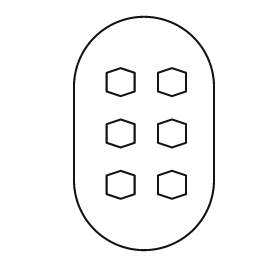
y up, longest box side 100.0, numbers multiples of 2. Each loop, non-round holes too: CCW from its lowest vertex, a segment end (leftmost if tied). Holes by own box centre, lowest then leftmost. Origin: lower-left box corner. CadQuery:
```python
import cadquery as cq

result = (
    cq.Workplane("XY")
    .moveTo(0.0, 30.0)
    .threePointArc((30.0, 0.0), (60.0, 30.0))
    .lineTo(60.0, 70.0)
    .threePointArc((30.0, 100.0), (0.0, 70.0))
    .close()
    .moveTo(20.0, 22.0)
    .lineTo(26.0, 24.0)
    .lineTo(26.0, 32.0)
    .lineTo(20.0, 34.0)
    .lineTo(14.0, 32.0)
    .lineTo(14.0, 24.0)
    .close()
    .moveTo(42.0, 22.0)
    .lineTo(48.0, 24.0)
    .lineTo(48.0, 32.0)
    .lineTo(42.0, 34.0)
    .lineTo(36.0, 32.0)
    .lineTo(36.0, 24.0)
    .close()
    .moveTo(20.0, 44.0)
    .lineTo(26.0, 46.0)
    .lineTo(26.0, 54.0)
    .lineTo(20.0, 56.0)
    .lineTo(14.0, 54.0)
    .lineTo(14.0, 46.0)
    .close()
    .moveTo(42.0, 44.0)
    .lineTo(48.0, 46.0)
    .lineTo(48.0, 54.0)
    .lineTo(42.0, 56.0)
    .lineTo(36.0, 54.0)
    .lineTo(36.0, 46.0)
    .close()
    .moveTo(20.0, 66.0)
    .lineTo(26.0, 68.0)
    .lineTo(26.0, 76.0)
    .lineTo(20.0, 78.0)
    .lineTo(14.0, 76.0)
    .lineTo(14.0, 68.0)
    .close()
    .moveTo(42.0, 66.0)
    .lineTo(48.0, 68.0)
    .lineTo(48.0, 76.0)
    .lineTo(42.0, 78.0)
    .lineTo(36.0, 76.0)
    .lineTo(36.0, 68.0)
    .close()
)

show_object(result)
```